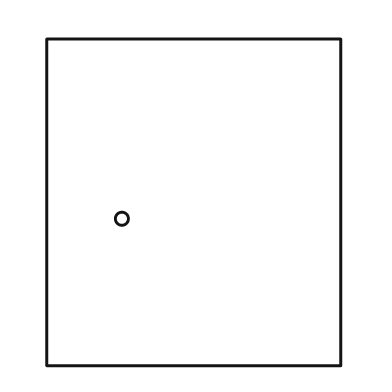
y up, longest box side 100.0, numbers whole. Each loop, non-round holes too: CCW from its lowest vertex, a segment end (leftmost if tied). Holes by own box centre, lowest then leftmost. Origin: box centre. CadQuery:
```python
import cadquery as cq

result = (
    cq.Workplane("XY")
    .moveTo(-45.0, -50.0)
    .lineTo(45.0, -50.0)
    .lineTo(45.0, 50.0)
    .lineTo(-45.0, 50.0)
    .close()
    .moveTo(-22.0, -5.0)
    .circle(2.0)
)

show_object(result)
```